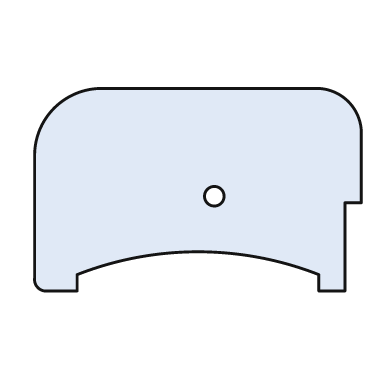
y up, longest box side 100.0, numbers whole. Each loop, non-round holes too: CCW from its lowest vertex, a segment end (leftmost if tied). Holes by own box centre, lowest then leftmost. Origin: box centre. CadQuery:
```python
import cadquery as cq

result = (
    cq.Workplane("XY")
    .moveTo(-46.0, -31.0)
    .lineTo(-37.0, -31.0)
    .lineTo(-37.0, -26.0)
    .threePointArc((0.0, -19.0), (37.0, -26.0))
    .lineTo(37.0, -31.0)
    .lineTo(45.0, -31.0)
    .lineTo(45.0, -4.0)
    .lineTo(50.0, -4.0)
    .lineTo(50.0, 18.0)
    .threePointArc((46.0, 27.0), (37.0, 31.0))
    .lineTo(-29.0, 31.0)
    .threePointArc((-44.0, 25.0), (-50.0, 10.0))
    .lineTo(-50.0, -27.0)
    .threePointArc((-49.0, -30.0), (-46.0, -31.0))
    .close()
    .moveTo(5.0, -2.0)
    .circle(3.0)
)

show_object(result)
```